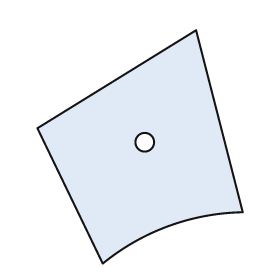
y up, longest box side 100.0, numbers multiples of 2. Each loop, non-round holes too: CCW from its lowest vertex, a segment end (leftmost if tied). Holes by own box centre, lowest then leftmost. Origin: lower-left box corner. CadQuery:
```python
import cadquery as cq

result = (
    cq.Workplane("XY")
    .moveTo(28.0, 0.0)
    .threePointArc((56.0, 16.0), (88.0, 22.0))
    .lineTo(68.0, 100.0)
    .lineTo(0.0, 58.0)
    .close()
    .moveTo(46.0, 52.0)
    .circle(4.0)
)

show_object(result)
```